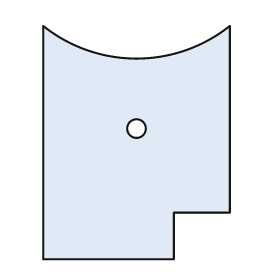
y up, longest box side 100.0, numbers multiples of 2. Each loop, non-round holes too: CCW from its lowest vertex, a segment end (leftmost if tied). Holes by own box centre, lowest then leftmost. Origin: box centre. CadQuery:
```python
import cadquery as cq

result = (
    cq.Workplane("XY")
    .moveTo(-40.0, -50.0)
    .lineTo(16.0, -50.0)
    .lineTo(16.0, -30.0)
    .lineTo(40.0, -30.0)
    .lineTo(40.0, 50.0)
    .threePointArc((0.0, 36.0), (-40.0, 50.0))
    .close()
    .moveTo(0.0, 6.0)
    .circle(4.0)
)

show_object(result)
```